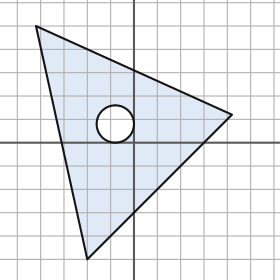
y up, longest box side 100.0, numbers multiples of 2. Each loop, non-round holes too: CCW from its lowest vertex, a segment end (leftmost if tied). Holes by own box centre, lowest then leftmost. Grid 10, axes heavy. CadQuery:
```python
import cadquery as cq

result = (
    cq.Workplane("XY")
    .moveTo(-20.0, -50.0)
    .lineTo(42.0, 12.0)
    .lineTo(-42.0, 50.0)
    .close()
    .moveTo(-8.0, 8.0)
    .circle(8.0)
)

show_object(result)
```